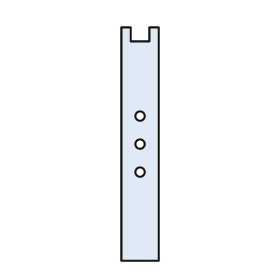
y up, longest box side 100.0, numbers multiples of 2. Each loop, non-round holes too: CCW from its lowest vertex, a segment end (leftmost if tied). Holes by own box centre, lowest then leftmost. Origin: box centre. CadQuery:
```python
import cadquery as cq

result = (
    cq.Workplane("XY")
    .moveTo(-8.0, -50.0)
    .lineTo(8.0, -50.0)
    .lineTo(8.0, 50.0)
    .lineTo(4.0, 50.0)
    .lineTo(4.0, 44.0)
    .lineTo(-4.0, 44.0)
    .lineTo(-4.0, 50.0)
    .lineTo(-8.0, 50.0)
    .close()
    .moveTo(0.0, -12.0)
    .circle(2.0)
    .moveTo(0.0, 0.0)
    .circle(2.0)
    .moveTo(0.0, 12.0)
    .circle(2.0)
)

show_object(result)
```